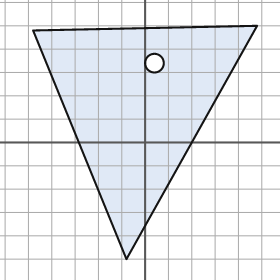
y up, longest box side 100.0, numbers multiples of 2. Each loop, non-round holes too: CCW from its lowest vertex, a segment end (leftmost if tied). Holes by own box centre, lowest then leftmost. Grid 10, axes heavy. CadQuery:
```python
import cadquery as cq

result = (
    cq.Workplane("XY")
    .moveTo(-8.0, -50.0)
    .lineTo(48.0, 50.0)
    .lineTo(-48.0, 48.0)
    .close()
    .moveTo(4.0, 34.0)
    .circle(4.0)
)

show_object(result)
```